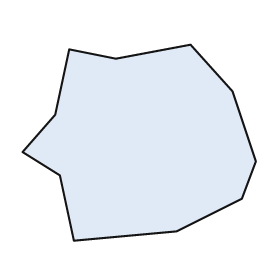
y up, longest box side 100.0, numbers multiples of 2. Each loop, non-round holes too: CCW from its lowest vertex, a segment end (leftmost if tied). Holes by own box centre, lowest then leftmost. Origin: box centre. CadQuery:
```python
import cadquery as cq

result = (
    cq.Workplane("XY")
    .moveTo(-28.0, -42.0)
    .lineTo(16.0, -38.0)
    .lineTo(44.0, -24.0)
    .lineTo(50.0, -8.0)
    .lineTo(40.0, 22.0)
    .lineTo(22.0, 42.0)
    .lineTo(-10.0, 36.0)
    .lineTo(-30.0, 40.0)
    .lineTo(-36.0, 12.0)
    .lineTo(-50.0, -4.0)
    .lineTo(-34.0, -14.0)
    .close()
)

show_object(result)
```